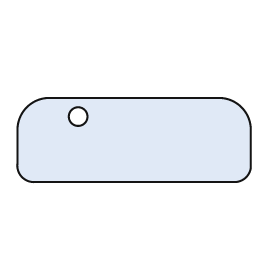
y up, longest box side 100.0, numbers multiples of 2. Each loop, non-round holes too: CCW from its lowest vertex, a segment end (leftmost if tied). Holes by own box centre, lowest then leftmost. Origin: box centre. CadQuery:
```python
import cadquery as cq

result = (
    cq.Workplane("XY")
    .moveTo(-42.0, -18.0)
    .lineTo(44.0, -18.0)
    .threePointArc((48.0, -16.0), (50.0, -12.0))
    .lineTo(50.0, 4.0)
    .threePointArc((46.0, 14.0), (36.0, 18.0))
    .lineTo(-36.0, 18.0)
    .threePointArc((-46.0, 14.0), (-50.0, 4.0))
    .lineTo(-50.0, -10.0)
    .threePointArc((-48.0, -16.0), (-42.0, -18.0))
    .close()
    .moveTo(-24.0, 10.0)
    .circle(4.0)
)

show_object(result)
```